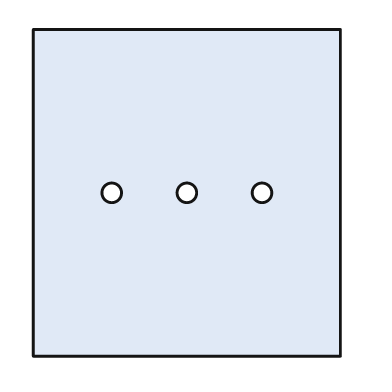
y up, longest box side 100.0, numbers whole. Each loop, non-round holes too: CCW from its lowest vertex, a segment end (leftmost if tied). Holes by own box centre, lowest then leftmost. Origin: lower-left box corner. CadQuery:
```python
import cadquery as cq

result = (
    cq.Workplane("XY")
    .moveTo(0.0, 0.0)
    .lineTo(94.0, 0.0)
    .lineTo(94.0, 100.0)
    .lineTo(0.0, 100.0)
    .close()
    .moveTo(24.0, 50.0)
    .circle(3.0)
    .moveTo(47.0, 50.0)
    .circle(3.0)
    .moveTo(70.0, 50.0)
    .circle(3.0)
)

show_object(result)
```